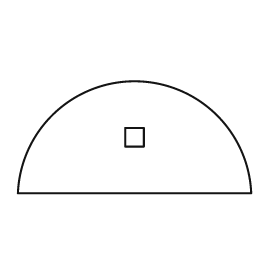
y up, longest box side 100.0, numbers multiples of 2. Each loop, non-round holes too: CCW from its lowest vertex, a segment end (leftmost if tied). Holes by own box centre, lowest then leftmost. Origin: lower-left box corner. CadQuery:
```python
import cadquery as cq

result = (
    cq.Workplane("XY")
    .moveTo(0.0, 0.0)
    .lineTo(100.0, 0.0)
    .threePointArc((50.0, 48.0), (0.0, 0.0))
    .close()
    .moveTo(46.0, 20.0)
    .lineTo(54.0, 20.0)
    .lineTo(54.0, 28.0)
    .lineTo(46.0, 28.0)
    .close()
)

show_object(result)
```